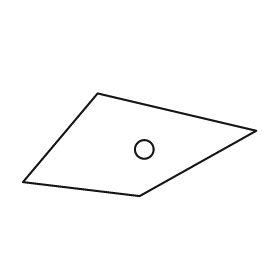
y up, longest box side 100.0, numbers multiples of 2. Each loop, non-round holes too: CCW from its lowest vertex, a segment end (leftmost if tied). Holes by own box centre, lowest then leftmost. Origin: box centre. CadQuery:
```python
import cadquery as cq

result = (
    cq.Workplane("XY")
    .moveTo(0.0, -22.0)
    .lineTo(50.0, 6.0)
    .lineTo(-18.0, 22.0)
    .lineTo(-50.0, -16.0)
    .close()
    .moveTo(2.0, -2.0)
    .circle(4.0)
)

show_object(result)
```